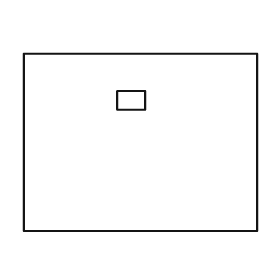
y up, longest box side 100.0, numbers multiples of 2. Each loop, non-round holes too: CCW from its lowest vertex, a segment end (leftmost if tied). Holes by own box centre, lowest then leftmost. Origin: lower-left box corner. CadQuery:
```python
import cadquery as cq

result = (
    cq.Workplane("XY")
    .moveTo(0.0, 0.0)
    .lineTo(100.0, 0.0)
    .lineTo(100.0, 76.0)
    .lineTo(0.0, 76.0)
    .close()
    .moveTo(40.0, 52.0)
    .lineTo(52.0, 52.0)
    .lineTo(52.0, 60.0)
    .lineTo(40.0, 60.0)
    .close()
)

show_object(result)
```